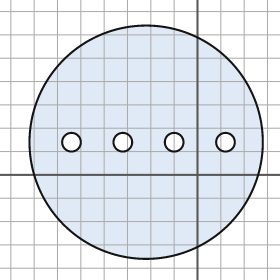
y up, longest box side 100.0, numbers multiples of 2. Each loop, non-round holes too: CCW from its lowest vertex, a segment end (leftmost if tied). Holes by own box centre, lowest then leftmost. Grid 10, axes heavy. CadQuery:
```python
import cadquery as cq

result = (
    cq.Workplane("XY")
    .moveTo(-22.0, 14.0)
    .circle(50.0)
    .moveTo(-54.0, 14.0)
    .circle(4.0)
    .moveTo(-32.0, 14.0)
    .circle(4.0)
    .moveTo(-10.0, 14.0)
    .circle(4.0)
    .moveTo(12.0, 14.0)
    .circle(4.0)
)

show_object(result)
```